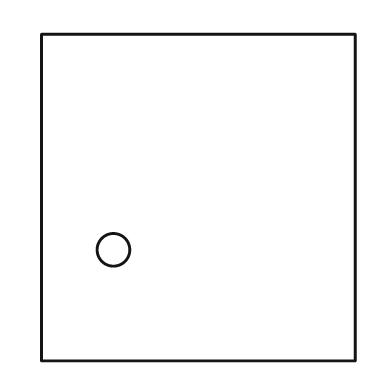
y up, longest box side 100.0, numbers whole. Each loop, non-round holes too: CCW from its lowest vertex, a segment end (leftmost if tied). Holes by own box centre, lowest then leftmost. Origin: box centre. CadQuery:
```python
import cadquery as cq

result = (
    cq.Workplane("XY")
    .moveTo(-48.0, -50.0)
    .lineTo(48.0, -50.0)
    .lineTo(48.0, 50.0)
    .lineTo(-48.0, 50.0)
    .close()
    .moveTo(-26.0, -16.0)
    .circle(5.0)
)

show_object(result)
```